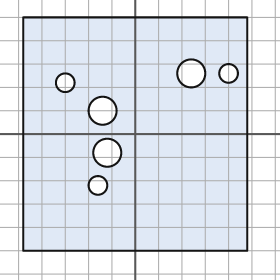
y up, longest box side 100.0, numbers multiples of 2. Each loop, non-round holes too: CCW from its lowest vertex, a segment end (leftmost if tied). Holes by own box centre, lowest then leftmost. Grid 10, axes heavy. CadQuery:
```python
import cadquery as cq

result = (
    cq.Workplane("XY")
    .moveTo(-48.0, -50.0)
    .lineTo(48.0, -50.0)
    .lineTo(48.0, 50.0)
    .lineTo(-48.0, 50.0)
    .close()
    .moveTo(-16.0, -22.0)
    .circle(4.0)
    .moveTo(-12.0, -8.0)
    .circle(6.0)
    .moveTo(-14.0, 10.0)
    .circle(6.0)
    .moveTo(-30.0, 22.0)
    .circle(4.0)
    .moveTo(24.0, 26.0)
    .circle(6.0)
    .moveTo(40.0, 26.0)
    .circle(4.0)
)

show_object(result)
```